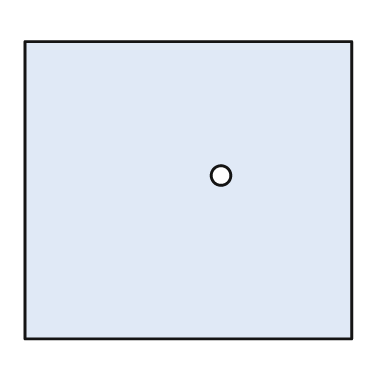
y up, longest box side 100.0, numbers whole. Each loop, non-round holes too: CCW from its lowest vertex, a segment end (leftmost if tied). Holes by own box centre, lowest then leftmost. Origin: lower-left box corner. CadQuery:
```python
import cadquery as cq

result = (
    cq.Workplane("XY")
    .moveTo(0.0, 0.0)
    .lineTo(100.0, 0.0)
    .lineTo(100.0, 91.0)
    .lineTo(0.0, 91.0)
    .close()
    .moveTo(60.0, 50.0)
    .circle(3.0)
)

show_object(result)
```